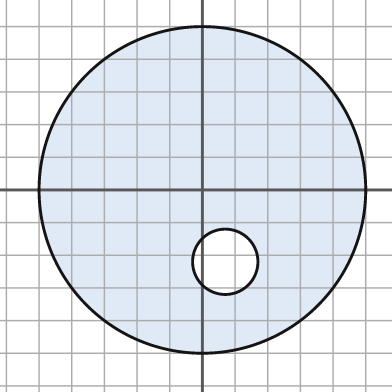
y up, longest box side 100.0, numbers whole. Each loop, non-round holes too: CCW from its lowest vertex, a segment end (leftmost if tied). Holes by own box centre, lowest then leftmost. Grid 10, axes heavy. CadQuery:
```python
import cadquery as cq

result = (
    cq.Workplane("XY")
    .moveTo(0.0, 0.0)
    .circle(50.0)
    .moveTo(7.0, -22.0)
    .circle(10.0)
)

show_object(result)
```